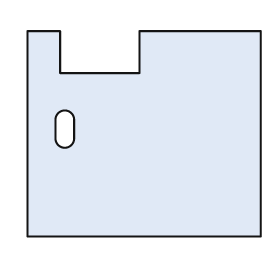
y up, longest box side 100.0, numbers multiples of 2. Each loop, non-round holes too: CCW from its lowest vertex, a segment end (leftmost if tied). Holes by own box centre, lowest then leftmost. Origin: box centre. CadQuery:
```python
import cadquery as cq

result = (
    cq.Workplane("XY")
    .moveTo(-50.0, -44.0)
    .lineTo(50.0, -44.0)
    .lineTo(50.0, 44.0)
    .lineTo(-2.0, 44.0)
    .lineTo(-2.0, 26.0)
    .lineTo(-36.0, 26.0)
    .lineTo(-36.0, 44.0)
    .lineTo(-50.0, 44.0)
    .close()
    .moveTo(-38.0, -2.0)
    .threePointArc((-34.0, -6.0), (-30.0, -2.0))
    .lineTo(-30.0, 6.0)
    .threePointArc((-34.0, 10.0), (-38.0, 6.0))
    .close()
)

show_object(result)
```